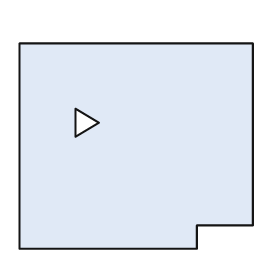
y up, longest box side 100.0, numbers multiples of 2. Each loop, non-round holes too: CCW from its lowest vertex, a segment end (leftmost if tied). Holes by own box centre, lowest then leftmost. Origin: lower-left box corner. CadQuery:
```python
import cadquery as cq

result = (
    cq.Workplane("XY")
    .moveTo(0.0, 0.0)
    .lineTo(76.0, 0.0)
    .lineTo(76.0, 10.0)
    .lineTo(100.0, 10.0)
    .lineTo(100.0, 88.0)
    .lineTo(0.0, 88.0)
    .close()
    .moveTo(24.0, 48.0)
    .lineTo(34.0, 54.0)
    .lineTo(24.0, 60.0)
    .close()
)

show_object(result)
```